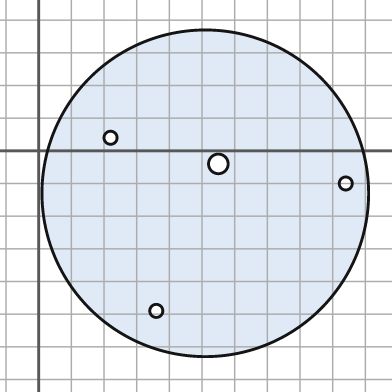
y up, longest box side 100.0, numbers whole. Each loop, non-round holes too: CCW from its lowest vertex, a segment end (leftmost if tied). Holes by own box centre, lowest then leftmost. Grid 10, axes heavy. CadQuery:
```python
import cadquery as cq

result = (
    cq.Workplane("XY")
    .moveTo(51.0, -13.0)
    .circle(50.0)
    .moveTo(36.0, -49.0)
    .circle(2.0)
    .moveTo(94.0, -10.0)
    .circle(2.0)
    .moveTo(55.0, -4.0)
    .circle(3.0)
    .moveTo(22.0, 4.0)
    .circle(2.0)
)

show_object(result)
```